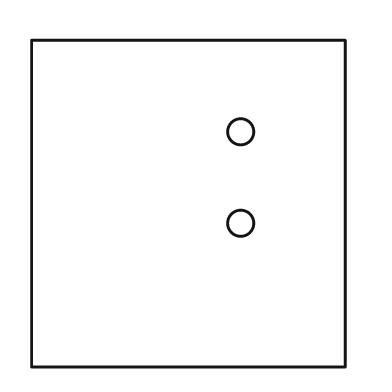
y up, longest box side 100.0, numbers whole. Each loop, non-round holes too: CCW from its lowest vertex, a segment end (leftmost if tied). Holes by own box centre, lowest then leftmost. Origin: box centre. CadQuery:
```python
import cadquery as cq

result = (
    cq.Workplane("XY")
    .moveTo(-48.0, -50.0)
    .lineTo(48.0, -50.0)
    .lineTo(48.0, 50.0)
    .lineTo(-48.0, 50.0)
    .close()
    .moveTo(16.0, -6.0)
    .circle(4.0)
    .moveTo(16.0, 22.0)
    .circle(4.0)
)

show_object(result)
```